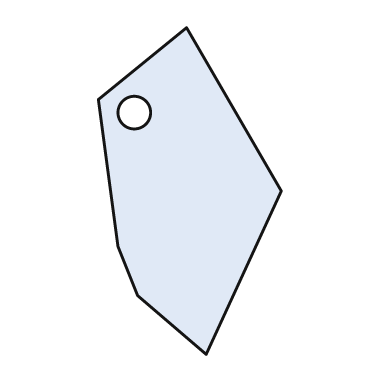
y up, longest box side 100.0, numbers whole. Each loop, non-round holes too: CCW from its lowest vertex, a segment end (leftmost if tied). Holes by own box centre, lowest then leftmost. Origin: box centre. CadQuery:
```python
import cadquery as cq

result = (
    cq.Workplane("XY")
    .moveTo(5.0, -50.0)
    .lineTo(28.0, 0.0)
    .lineTo(-1.0, 50.0)
    .lineTo(-28.0, 28.0)
    .lineTo(-22.0, -17.0)
    .lineTo(-16.0, -32.0)
    .close()
    .moveTo(-17.0, 24.0)
    .circle(5.0)
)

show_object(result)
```